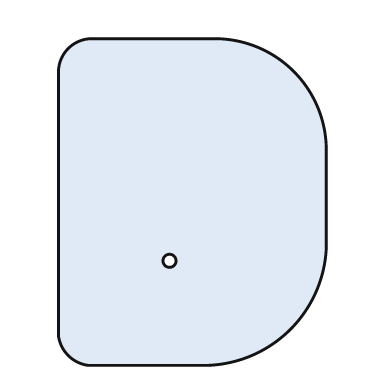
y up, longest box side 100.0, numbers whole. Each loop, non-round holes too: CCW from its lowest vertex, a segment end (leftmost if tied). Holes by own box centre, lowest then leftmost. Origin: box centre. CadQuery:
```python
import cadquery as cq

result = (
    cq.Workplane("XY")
    .moveTo(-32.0, -50.0)
    .lineTo(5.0, -50.0)
    .threePointArc((30.0, -39.0), (41.0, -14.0))
    .lineTo(41.0, 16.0)
    .threePointArc((31.0, 40.0), (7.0, 50.0))
    .lineTo(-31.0, 50.0)
    .threePointArc((-38.0, 47.0), (-41.0, 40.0))
    .lineTo(-41.0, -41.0)
    .threePointArc((-38.0, -47.0), (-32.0, -50.0))
    .close()
    .moveTo(-7.0, -18.0)
    .circle(2.0)
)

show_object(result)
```